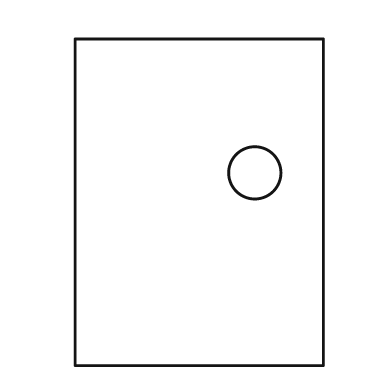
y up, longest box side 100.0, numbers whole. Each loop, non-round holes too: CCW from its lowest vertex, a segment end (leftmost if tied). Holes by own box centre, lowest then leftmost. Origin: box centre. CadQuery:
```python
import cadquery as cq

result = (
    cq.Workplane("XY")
    .moveTo(-38.0, -50.0)
    .lineTo(38.0, -50.0)
    .lineTo(38.0, 50.0)
    .lineTo(-38.0, 50.0)
    .close()
    .moveTo(17.0, 9.0)
    .circle(8.0)
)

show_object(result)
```